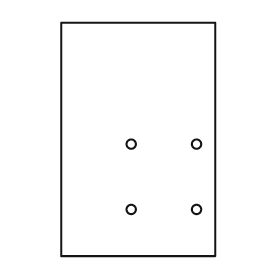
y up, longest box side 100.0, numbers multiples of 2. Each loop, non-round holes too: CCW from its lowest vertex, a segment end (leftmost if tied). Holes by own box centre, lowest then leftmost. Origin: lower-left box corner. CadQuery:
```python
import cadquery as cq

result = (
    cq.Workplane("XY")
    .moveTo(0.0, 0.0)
    .lineTo(66.0, 0.0)
    .lineTo(66.0, 100.0)
    .lineTo(0.0, 100.0)
    .close()
    .moveTo(30.0, 20.0)
    .circle(2.0)
    .moveTo(58.0, 20.0)
    .circle(2.0)
    .moveTo(30.0, 48.0)
    .circle(2.0)
    .moveTo(58.0, 48.0)
    .circle(2.0)
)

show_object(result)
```